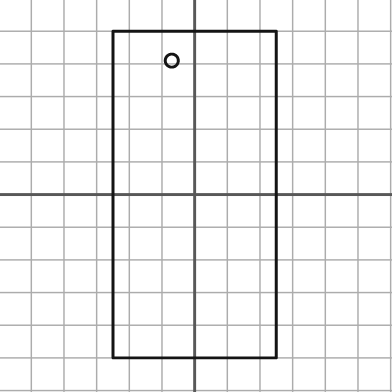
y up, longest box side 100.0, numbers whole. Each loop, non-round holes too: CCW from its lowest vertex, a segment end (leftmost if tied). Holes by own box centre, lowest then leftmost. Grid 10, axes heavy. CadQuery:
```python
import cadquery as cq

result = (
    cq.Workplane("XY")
    .moveTo(-25.0, -50.0)
    .lineTo(25.0, -50.0)
    .lineTo(25.0, 50.0)
    .lineTo(-25.0, 50.0)
    .close()
    .moveTo(-7.0, 41.0)
    .circle(2.0)
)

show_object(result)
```